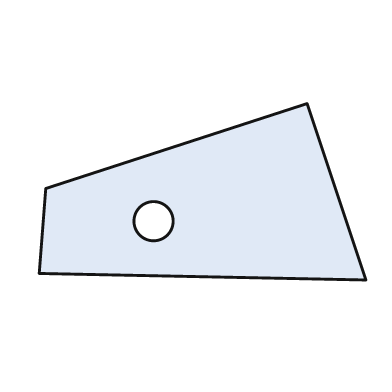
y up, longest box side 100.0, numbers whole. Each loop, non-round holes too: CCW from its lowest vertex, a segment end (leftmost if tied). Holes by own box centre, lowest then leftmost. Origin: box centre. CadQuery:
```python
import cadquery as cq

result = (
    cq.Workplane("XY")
    .moveTo(50.0, -27.0)
    .lineTo(32.0, 27.0)
    .lineTo(-48.0, 1.0)
    .lineTo(-50.0, -25.0)
    .close()
    .moveTo(-15.0, -9.0)
    .circle(6.0)
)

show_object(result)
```